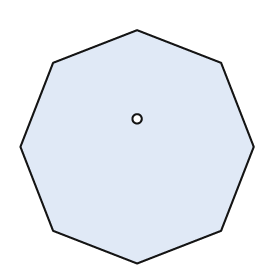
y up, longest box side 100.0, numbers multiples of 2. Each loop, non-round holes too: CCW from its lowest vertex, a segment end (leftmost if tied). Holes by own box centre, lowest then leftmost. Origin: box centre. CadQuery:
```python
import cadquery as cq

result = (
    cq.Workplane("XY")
    .moveTo(0.0, -50.0)
    .lineTo(36.0, -36.0)
    .lineTo(50.0, 0.0)
    .lineTo(36.0, 36.0)
    .lineTo(0.0, 50.0)
    .lineTo(-36.0, 36.0)
    .lineTo(-50.0, 0.0)
    .lineTo(-36.0, -36.0)
    .close()
    .moveTo(0.0, 12.0)
    .circle(2.0)
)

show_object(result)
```